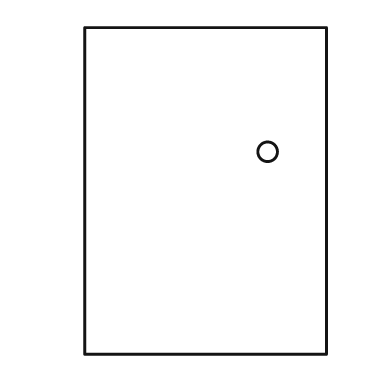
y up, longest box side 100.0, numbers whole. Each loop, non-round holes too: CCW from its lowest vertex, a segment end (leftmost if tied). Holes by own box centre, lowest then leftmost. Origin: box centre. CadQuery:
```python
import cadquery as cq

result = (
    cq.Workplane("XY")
    .moveTo(-37.0, -50.0)
    .lineTo(37.0, -50.0)
    .lineTo(37.0, 50.0)
    .lineTo(-37.0, 50.0)
    .close()
    .moveTo(19.0, 12.0)
    .circle(3.0)
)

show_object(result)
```